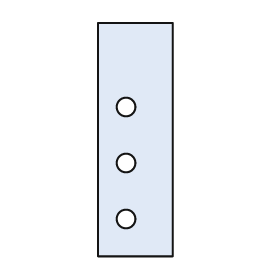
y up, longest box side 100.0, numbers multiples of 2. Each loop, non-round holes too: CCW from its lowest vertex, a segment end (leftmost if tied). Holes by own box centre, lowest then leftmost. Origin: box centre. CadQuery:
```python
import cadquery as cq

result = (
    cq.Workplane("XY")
    .moveTo(-16.0, -50.0)
    .lineTo(16.0, -50.0)
    .lineTo(16.0, 50.0)
    .lineTo(-16.0, 50.0)
    .close()
    .moveTo(-4.0, -34.0)
    .circle(4.0)
    .moveTo(-4.0, -10.0)
    .circle(4.0)
    .moveTo(-4.0, 14.0)
    .circle(4.0)
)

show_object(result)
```